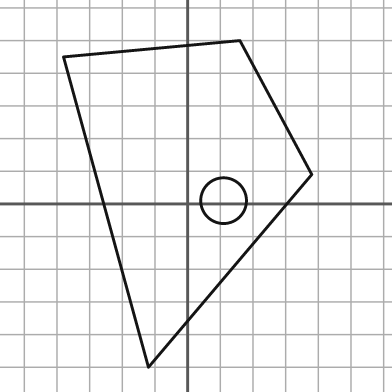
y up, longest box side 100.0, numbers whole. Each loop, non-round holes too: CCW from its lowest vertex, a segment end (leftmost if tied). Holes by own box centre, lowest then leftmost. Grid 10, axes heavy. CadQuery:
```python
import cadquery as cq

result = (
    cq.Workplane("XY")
    .moveTo(-12.0, -50.0)
    .lineTo(38.0, 9.0)
    .lineTo(16.0, 50.0)
    .lineTo(-38.0, 45.0)
    .close()
    .moveTo(11.0, 1.0)
    .circle(7.0)
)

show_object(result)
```